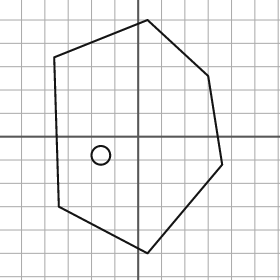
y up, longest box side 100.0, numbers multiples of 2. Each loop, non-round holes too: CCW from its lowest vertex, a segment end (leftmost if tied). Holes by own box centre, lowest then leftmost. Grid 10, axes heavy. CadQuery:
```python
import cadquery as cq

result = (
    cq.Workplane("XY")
    .moveTo(4.0, -50.0)
    .lineTo(36.0, -12.0)
    .lineTo(30.0, 26.0)
    .lineTo(4.0, 50.0)
    .lineTo(-36.0, 34.0)
    .lineTo(-34.0, -30.0)
    .close()
    .moveTo(-16.0, -8.0)
    .circle(4.0)
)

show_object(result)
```